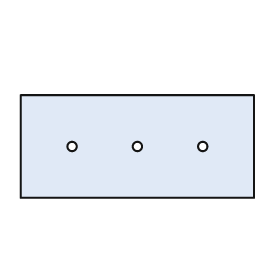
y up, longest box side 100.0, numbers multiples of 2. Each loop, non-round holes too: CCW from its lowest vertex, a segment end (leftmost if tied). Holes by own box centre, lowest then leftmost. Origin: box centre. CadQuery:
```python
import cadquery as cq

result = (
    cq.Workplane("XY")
    .moveTo(-50.0, -22.0)
    .lineTo(50.0, -22.0)
    .lineTo(50.0, 22.0)
    .lineTo(-50.0, 22.0)
    .close()
    .moveTo(-28.0, 0.0)
    .circle(2.0)
    .moveTo(0.0, 0.0)
    .circle(2.0)
    .moveTo(28.0, 0.0)
    .circle(2.0)
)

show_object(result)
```